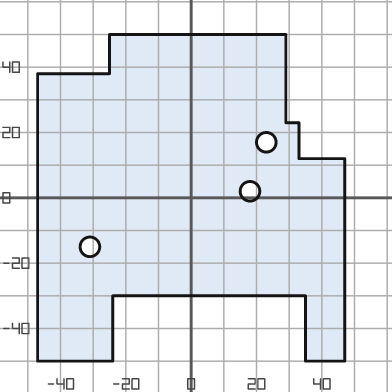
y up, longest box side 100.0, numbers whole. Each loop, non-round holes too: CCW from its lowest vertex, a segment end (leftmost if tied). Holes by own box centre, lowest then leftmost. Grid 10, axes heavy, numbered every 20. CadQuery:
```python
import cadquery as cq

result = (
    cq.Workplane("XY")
    .moveTo(-47.0, -50.0)
    .lineTo(-24.0, -50.0)
    .lineTo(-24.0, -30.0)
    .lineTo(35.0, -30.0)
    .lineTo(35.0, -50.0)
    .lineTo(47.0, -50.0)
    .lineTo(47.0, 12.0)
    .lineTo(33.0, 12.0)
    .lineTo(33.0, 23.0)
    .lineTo(29.0, 23.0)
    .lineTo(29.0, 50.0)
    .lineTo(-25.0, 50.0)
    .lineTo(-25.0, 38.0)
    .lineTo(-47.0, 38.0)
    .close()
    .moveTo(-31.0, -15.0)
    .circle(3.0)
    .moveTo(18.0, 2.0)
    .circle(3.0)
    .moveTo(23.0, 17.0)
    .circle(3.0)
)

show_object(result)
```